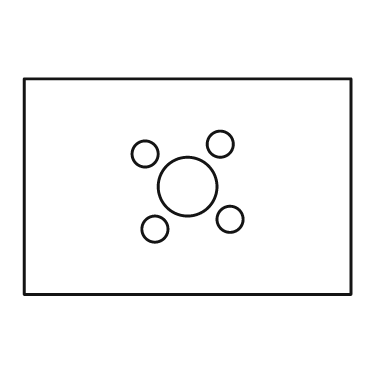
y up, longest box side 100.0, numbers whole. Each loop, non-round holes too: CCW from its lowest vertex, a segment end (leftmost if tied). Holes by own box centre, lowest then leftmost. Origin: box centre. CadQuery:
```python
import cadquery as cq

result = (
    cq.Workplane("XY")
    .moveTo(-50.0, -33.0)
    .lineTo(50.0, -33.0)
    .lineTo(50.0, 33.0)
    .lineTo(-50.0, 33.0)
    .close()
    .moveTo(-10.0, -13.0)
    .circle(4.0)
    .moveTo(13.0, -10.0)
    .circle(4.0)
    .moveTo(0.0, 0.0)
    .circle(9.0)
    .moveTo(-13.0, 10.0)
    .circle(4.0)
    .moveTo(10.0, 13.0)
    .circle(4.0)
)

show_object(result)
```